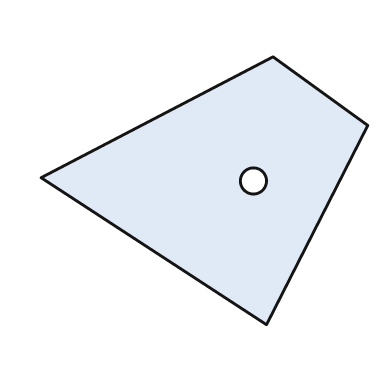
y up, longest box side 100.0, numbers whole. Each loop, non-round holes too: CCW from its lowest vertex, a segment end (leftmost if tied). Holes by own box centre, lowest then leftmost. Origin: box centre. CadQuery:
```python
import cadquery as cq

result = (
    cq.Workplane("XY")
    .moveTo(19.0, -41.0)
    .lineTo(50.0, 20.0)
    .lineTo(21.0, 41.0)
    .lineTo(-50.0, 4.0)
    .close()
    .moveTo(15.0, 3.0)
    .circle(4.0)
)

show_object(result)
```